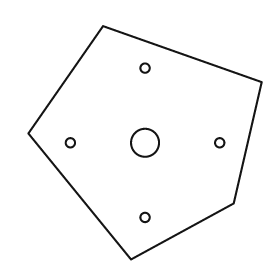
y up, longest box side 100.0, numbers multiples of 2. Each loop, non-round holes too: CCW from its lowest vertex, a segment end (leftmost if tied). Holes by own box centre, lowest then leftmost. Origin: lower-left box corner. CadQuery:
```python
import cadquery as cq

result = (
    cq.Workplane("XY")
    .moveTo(44.0, 0.0)
    .lineTo(88.0, 24.0)
    .lineTo(100.0, 76.0)
    .lineTo(32.0, 100.0)
    .lineTo(0.0, 54.0)
    .close()
    .moveTo(50.0, 18.0)
    .circle(2.0)
    .moveTo(18.0, 50.0)
    .circle(2.0)
    .moveTo(50.0, 50.0)
    .circle(6.0)
    .moveTo(82.0, 50.0)
    .circle(2.0)
    .moveTo(50.0, 82.0)
    .circle(2.0)
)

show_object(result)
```